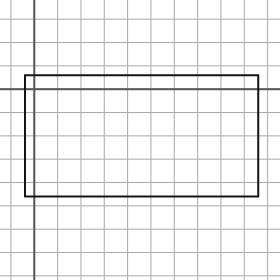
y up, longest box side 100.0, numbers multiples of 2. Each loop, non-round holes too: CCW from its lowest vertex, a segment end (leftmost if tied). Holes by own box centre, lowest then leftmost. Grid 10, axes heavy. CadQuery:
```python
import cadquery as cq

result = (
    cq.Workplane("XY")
    .moveTo(-4.0, -46.0)
    .lineTo(96.0, -46.0)
    .lineTo(96.0, 6.0)
    .lineTo(-4.0, 6.0)
    .close()
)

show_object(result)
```